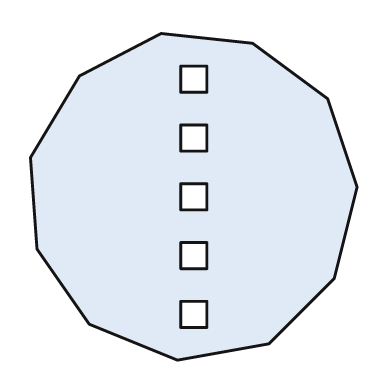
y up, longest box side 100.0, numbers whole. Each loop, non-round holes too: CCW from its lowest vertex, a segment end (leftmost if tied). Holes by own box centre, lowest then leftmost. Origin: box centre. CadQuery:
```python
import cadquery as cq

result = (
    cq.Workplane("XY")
    .moveTo(-5.0, -50.0)
    .lineTo(23.0, -45.0)
    .lineTo(43.0, -25.0)
    .lineTo(50.0, 3.0)
    .lineTo(41.0, 30.0)
    .lineTo(18.0, 47.0)
    .lineTo(-10.0, 50.0)
    .lineTo(-35.0, 37.0)
    .lineTo(-50.0, 12.0)
    .lineTo(-48.0, -16.0)
    .lineTo(-32.0, -39.0)
    .close()
    .moveTo(-4.0, -40.0)
    .lineTo(4.0, -40.0)
    .lineTo(4.0, -32.0)
    .lineTo(-4.0, -32.0)
    .close()
    .moveTo(-4.0, -22.0)
    .lineTo(4.0, -22.0)
    .lineTo(4.0, -14.0)
    .lineTo(-4.0, -14.0)
    .close()
    .moveTo(-4.0, -4.0)
    .lineTo(4.0, -4.0)
    .lineTo(4.0, 4.0)
    .lineTo(-4.0, 4.0)
    .close()
    .moveTo(-4.0, 14.0)
    .lineTo(4.0, 14.0)
    .lineTo(4.0, 22.0)
    .lineTo(-4.0, 22.0)
    .close()
    .moveTo(-4.0, 32.0)
    .lineTo(4.0, 32.0)
    .lineTo(4.0, 40.0)
    .lineTo(-4.0, 40.0)
    .close()
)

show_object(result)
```